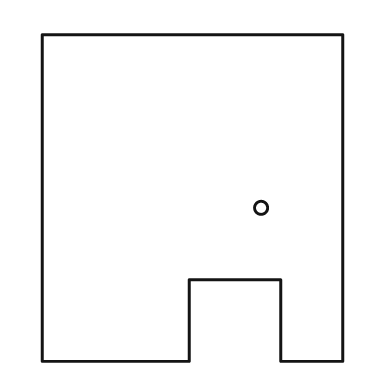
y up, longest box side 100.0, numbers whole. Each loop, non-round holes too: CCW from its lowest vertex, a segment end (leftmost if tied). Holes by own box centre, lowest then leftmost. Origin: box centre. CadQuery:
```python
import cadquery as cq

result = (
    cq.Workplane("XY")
    .moveTo(-46.0, -50.0)
    .lineTo(-1.0, -50.0)
    .lineTo(-1.0, -25.0)
    .lineTo(27.0, -25.0)
    .lineTo(27.0, -50.0)
    .lineTo(46.0, -50.0)
    .lineTo(46.0, 50.0)
    .lineTo(-46.0, 50.0)
    .close()
    .moveTo(21.0, -3.0)
    .circle(2.0)
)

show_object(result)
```